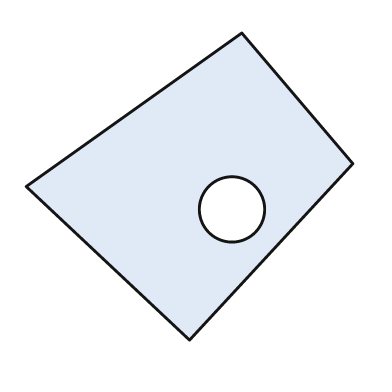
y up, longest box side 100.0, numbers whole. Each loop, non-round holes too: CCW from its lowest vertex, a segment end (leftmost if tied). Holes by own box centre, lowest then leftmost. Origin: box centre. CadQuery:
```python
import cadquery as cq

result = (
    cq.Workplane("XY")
    .moveTo(0.0, -47.0)
    .lineTo(50.0, 7.0)
    .lineTo(16.0, 47.0)
    .lineTo(-50.0, 0.0)
    .close()
    .moveTo(13.0, -7.0)
    .circle(10.0)
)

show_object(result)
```